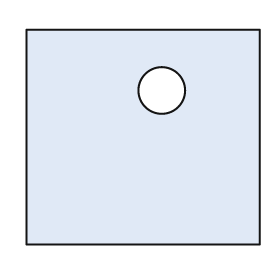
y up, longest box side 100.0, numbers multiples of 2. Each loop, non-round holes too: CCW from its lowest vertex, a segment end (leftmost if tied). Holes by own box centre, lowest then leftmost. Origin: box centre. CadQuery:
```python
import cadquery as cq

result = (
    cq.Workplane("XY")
    .moveTo(-50.0, -46.0)
    .lineTo(50.0, -46.0)
    .lineTo(50.0, 46.0)
    .lineTo(-50.0, 46.0)
    .close()
    .moveTo(8.0, 20.0)
    .circle(10.0)
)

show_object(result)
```